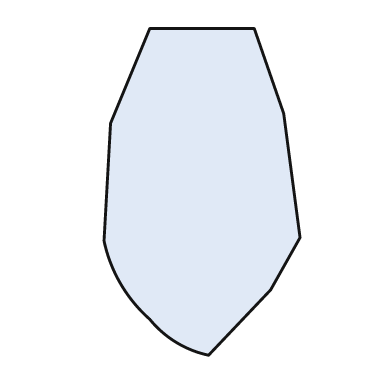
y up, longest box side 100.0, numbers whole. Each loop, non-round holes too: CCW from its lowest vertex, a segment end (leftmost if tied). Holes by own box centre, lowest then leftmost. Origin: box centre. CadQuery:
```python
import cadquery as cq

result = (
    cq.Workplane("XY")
    .moveTo(2.0, -50.0)
    .lineTo(21.0, -30.0)
    .lineTo(30.0, -14.0)
    .lineTo(25.0, 24.0)
    .lineTo(16.0, 50.0)
    .lineTo(-16.0, 50.0)
    .lineTo(-28.0, 21.0)
    .lineTo(-30.0, -15.0)
    .threePointArc((-25.0, -28.0), (-16.0, -39.0))
    .threePointArc((-8.0, -46.0), (2.0, -50.0))
    .close()
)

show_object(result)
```